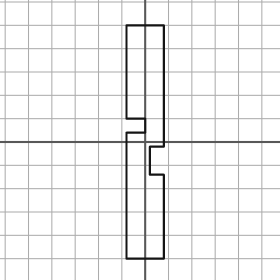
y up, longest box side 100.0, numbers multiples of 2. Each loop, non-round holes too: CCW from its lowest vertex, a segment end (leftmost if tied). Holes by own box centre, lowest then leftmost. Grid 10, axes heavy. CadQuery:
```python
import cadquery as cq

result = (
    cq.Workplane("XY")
    .moveTo(-8.0, -50.0)
    .lineTo(8.0, -50.0)
    .lineTo(8.0, -14.0)
    .lineTo(2.0, -14.0)
    .lineTo(2.0, -2.0)
    .lineTo(8.0, -2.0)
    .lineTo(8.0, 50.0)
    .lineTo(-8.0, 50.0)
    .lineTo(-8.0, 10.0)
    .lineTo(0.0, 10.0)
    .lineTo(0.0, 4.0)
    .lineTo(-8.0, 4.0)
    .close()
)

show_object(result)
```